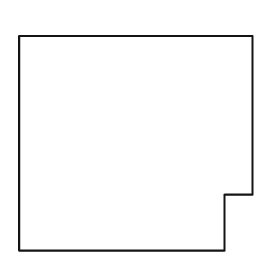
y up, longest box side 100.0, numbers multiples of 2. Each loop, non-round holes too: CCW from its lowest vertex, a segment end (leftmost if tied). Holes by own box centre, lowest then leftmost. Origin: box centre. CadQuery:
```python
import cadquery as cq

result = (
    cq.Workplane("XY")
    .moveTo(-50.0, -46.0)
    .lineTo(38.0, -46.0)
    .lineTo(38.0, -22.0)
    .lineTo(50.0, -22.0)
    .lineTo(50.0, 46.0)
    .lineTo(-50.0, 46.0)
    .close()
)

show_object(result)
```